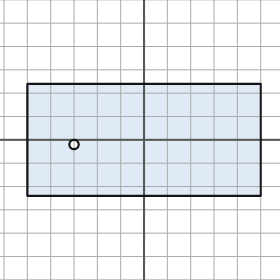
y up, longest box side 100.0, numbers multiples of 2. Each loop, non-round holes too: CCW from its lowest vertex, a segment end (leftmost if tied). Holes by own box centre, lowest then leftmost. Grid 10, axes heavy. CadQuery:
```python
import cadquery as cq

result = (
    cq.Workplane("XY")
    .moveTo(-50.0, -24.0)
    .lineTo(50.0, -24.0)
    .lineTo(50.0, 24.0)
    .lineTo(-50.0, 24.0)
    .close()
    .moveTo(-30.0, -2.0)
    .circle(2.0)
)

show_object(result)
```